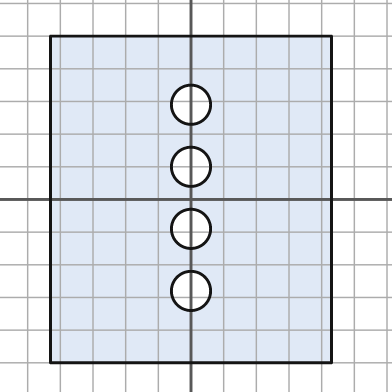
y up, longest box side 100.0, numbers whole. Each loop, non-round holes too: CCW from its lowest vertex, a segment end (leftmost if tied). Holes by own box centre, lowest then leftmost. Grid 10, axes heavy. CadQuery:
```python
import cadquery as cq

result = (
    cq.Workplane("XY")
    .moveTo(-43.0, -50.0)
    .lineTo(43.0, -50.0)
    .lineTo(43.0, 50.0)
    .lineTo(-43.0, 50.0)
    .close()
    .moveTo(0.0, -28.0)
    .circle(6.0)
    .moveTo(0.0, -9.0)
    .circle(6.0)
    .moveTo(0.0, 10.0)
    .circle(6.0)
    .moveTo(0.0, 29.0)
    .circle(6.0)
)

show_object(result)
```